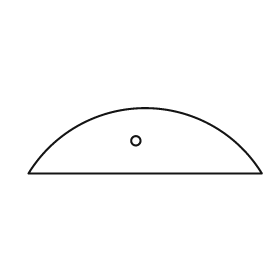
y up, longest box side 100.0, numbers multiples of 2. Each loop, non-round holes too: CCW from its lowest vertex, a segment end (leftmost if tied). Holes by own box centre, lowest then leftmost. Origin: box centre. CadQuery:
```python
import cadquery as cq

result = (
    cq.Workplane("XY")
    .moveTo(-50.0, -14.0)
    .lineTo(50.0, -14.0)
    .threePointArc((0.0, 14.0), (-50.0, -14.0))
    .close()
    .moveTo(-4.0, 0.0)
    .circle(2.0)
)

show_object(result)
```